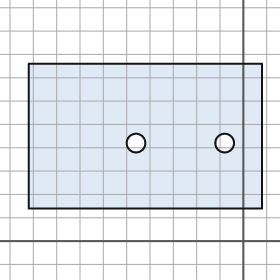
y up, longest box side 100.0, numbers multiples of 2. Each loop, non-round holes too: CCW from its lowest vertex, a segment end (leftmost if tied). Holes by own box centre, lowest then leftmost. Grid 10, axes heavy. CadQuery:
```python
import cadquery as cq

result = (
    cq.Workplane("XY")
    .moveTo(-92.0, 14.0)
    .lineTo(8.0, 14.0)
    .lineTo(8.0, 76.0)
    .lineTo(-92.0, 76.0)
    .close()
    .moveTo(-46.0, 42.0)
    .circle(4.0)
    .moveTo(-8.0, 42.0)
    .circle(4.0)
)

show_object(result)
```